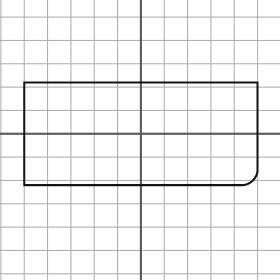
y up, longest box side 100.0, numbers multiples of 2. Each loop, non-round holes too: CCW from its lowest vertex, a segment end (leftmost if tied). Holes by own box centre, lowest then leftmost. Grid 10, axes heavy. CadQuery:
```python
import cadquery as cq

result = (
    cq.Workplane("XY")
    .moveTo(-50.0, -22.0)
    .lineTo(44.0, -22.0)
    .threePointArc((48.0, -20.0), (50.0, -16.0))
    .lineTo(50.0, 22.0)
    .lineTo(-50.0, 22.0)
    .close()
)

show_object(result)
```